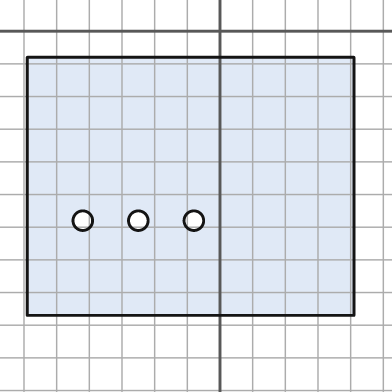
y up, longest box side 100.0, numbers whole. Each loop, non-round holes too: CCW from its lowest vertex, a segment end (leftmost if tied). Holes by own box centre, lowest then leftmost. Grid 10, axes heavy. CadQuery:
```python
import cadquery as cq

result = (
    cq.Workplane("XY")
    .moveTo(-59.0, -87.0)
    .lineTo(41.0, -87.0)
    .lineTo(41.0, -8.0)
    .lineTo(-59.0, -8.0)
    .close()
    .moveTo(-42.0, -58.0)
    .circle(3.0)
    .moveTo(-25.0, -58.0)
    .circle(3.0)
    .moveTo(-8.0, -58.0)
    .circle(3.0)
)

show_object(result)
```